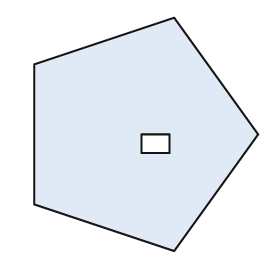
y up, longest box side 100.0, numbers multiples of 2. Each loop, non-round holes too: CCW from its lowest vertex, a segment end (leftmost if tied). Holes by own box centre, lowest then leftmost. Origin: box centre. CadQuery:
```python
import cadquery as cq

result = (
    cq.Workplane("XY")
    .moveTo(12.0, -50.0)
    .lineTo(48.0, 0.0)
    .lineTo(12.0, 50.0)
    .lineTo(-48.0, 30.0)
    .lineTo(-48.0, -30.0)
    .close()
    .moveTo(-2.0, -8.0)
    .lineTo(10.0, -8.0)
    .lineTo(10.0, 0.0)
    .lineTo(-2.0, 0.0)
    .close()
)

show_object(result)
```